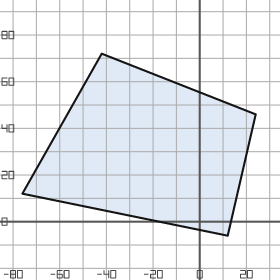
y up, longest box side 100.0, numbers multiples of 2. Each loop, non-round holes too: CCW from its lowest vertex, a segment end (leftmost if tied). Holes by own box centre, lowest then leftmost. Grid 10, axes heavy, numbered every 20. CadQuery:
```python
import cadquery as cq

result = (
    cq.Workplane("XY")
    .moveTo(12.0, -6.0)
    .lineTo(24.0, 46.0)
    .lineTo(-42.0, 72.0)
    .lineTo(-76.0, 12.0)
    .close()
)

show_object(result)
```